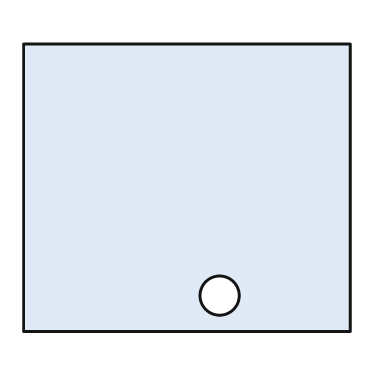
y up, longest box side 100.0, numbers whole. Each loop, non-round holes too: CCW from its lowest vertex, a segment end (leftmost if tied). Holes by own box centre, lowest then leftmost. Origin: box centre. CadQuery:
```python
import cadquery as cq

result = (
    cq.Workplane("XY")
    .moveTo(-50.0, -44.0)
    .lineTo(50.0, -44.0)
    .lineTo(50.0, 44.0)
    .lineTo(-50.0, 44.0)
    .close()
    .moveTo(10.0, -33.0)
    .circle(6.0)
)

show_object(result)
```